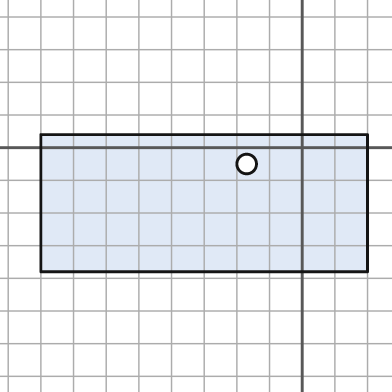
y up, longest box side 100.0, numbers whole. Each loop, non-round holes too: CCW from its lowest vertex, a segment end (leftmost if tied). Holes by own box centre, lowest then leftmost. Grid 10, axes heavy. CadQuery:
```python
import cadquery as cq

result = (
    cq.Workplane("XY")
    .moveTo(-80.0, -38.0)
    .lineTo(20.0, -38.0)
    .lineTo(20.0, 4.0)
    .lineTo(-80.0, 4.0)
    .close()
    .moveTo(-17.0, -5.0)
    .circle(3.0)
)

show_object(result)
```